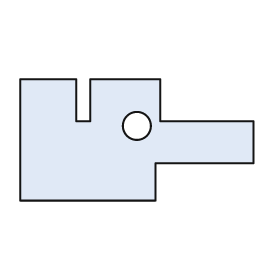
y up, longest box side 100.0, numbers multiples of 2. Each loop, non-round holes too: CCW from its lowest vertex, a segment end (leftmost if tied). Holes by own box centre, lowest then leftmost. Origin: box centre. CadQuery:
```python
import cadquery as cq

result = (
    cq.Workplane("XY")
    .moveTo(-50.0, -26.0)
    .lineTo(8.0, -26.0)
    .lineTo(8.0, -10.0)
    .lineTo(50.0, -10.0)
    .lineTo(50.0, 8.0)
    .lineTo(10.0, 8.0)
    .lineTo(10.0, 26.0)
    .lineTo(-20.0, 26.0)
    .lineTo(-20.0, 8.0)
    .lineTo(-26.0, 8.0)
    .lineTo(-26.0, 26.0)
    .lineTo(-50.0, 26.0)
    .close()
    .moveTo(0.0, 6.0)
    .circle(6.0)
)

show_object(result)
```